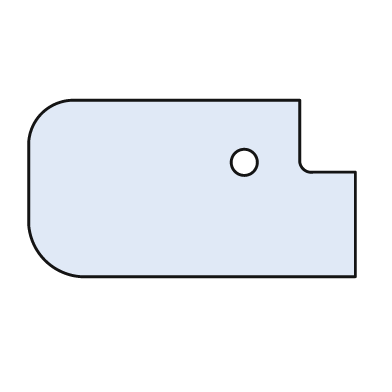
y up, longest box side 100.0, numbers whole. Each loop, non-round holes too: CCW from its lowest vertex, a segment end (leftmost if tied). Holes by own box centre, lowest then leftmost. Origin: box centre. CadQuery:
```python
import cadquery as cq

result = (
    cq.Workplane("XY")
    .moveTo(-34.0, -27.0)
    .lineTo(50.0, -27.0)
    .lineTo(50.0, 5.0)
    .lineTo(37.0, 5.0)
    .threePointArc((34.0, 6.0), (33.0, 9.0))
    .lineTo(33.0, 27.0)
    .lineTo(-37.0, 27.0)
    .threePointArc((-46.0, 23.0), (-50.0, 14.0))
    .lineTo(-50.0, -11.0)
    .threePointArc((-45.0, -22.0), (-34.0, -27.0))
    .close()
    .moveTo(16.0, 8.0)
    .circle(4.0)
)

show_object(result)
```